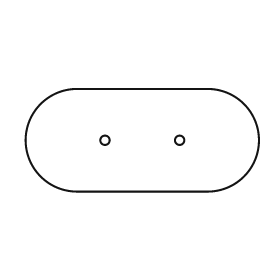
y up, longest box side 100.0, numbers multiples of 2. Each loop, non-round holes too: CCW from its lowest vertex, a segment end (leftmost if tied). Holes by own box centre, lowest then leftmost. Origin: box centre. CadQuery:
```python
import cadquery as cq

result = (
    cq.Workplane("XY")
    .moveTo(-28.0, -22.0)
    .lineTo(28.0, -22.0)
    .threePointArc((50.0, 0.0), (28.0, 22.0))
    .lineTo(-28.0, 22.0)
    .threePointArc((-50.0, 0.0), (-28.0, -22.0))
    .close()
    .moveTo(-16.0, 0.0)
    .circle(2.0)
    .moveTo(16.0, 0.0)
    .circle(2.0)
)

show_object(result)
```